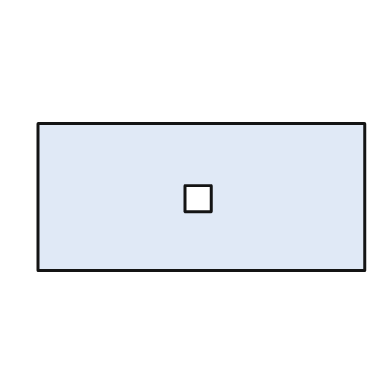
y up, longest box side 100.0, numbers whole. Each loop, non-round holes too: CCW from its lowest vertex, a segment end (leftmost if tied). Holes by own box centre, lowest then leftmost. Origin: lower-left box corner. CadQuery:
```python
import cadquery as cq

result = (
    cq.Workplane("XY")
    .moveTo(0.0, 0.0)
    .lineTo(100.0, 0.0)
    .lineTo(100.0, 45.0)
    .lineTo(0.0, 45.0)
    .close()
    .moveTo(45.0, 18.0)
    .lineTo(53.0, 18.0)
    .lineTo(53.0, 26.0)
    .lineTo(45.0, 26.0)
    .close()
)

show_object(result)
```